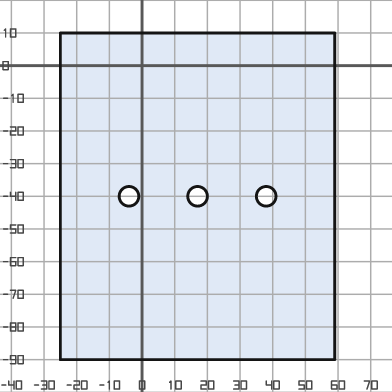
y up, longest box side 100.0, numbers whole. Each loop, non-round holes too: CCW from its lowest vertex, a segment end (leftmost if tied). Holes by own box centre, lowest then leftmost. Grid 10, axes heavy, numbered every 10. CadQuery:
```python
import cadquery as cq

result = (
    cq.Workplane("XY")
    .moveTo(-25.0, -90.0)
    .lineTo(59.0, -90.0)
    .lineTo(59.0, 10.0)
    .lineTo(-25.0, 10.0)
    .close()
    .moveTo(-4.0, -40.0)
    .circle(3.0)
    .moveTo(17.0, -40.0)
    .circle(3.0)
    .moveTo(38.0, -40.0)
    .circle(3.0)
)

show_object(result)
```